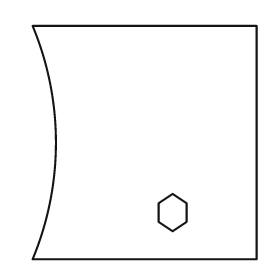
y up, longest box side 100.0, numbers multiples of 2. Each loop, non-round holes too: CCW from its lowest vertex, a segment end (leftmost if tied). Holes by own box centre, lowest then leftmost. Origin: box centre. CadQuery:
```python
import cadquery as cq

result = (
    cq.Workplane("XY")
    .moveTo(-48.0, -50.0)
    .lineTo(48.0, -50.0)
    .lineTo(48.0, 50.0)
    .lineTo(-48.0, 50.0)
    .threePointArc((-38.0, 0.0), (-48.0, -50.0))
    .close()
    .moveTo(12.0, -38.0)
    .lineTo(18.0, -34.0)
    .lineTo(18.0, -26.0)
    .lineTo(12.0, -22.0)
    .lineTo(6.0, -26.0)
    .lineTo(6.0, -34.0)
    .close()
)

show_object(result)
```